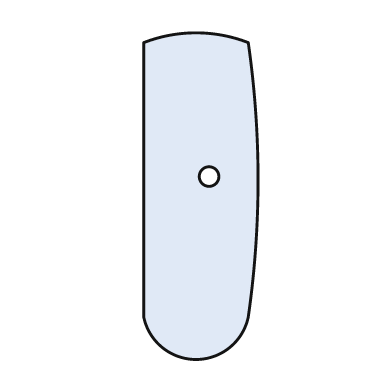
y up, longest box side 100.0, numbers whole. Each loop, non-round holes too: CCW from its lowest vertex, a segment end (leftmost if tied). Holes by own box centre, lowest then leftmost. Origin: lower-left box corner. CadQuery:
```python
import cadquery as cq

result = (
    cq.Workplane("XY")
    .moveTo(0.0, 13.0)
    .threePointArc((16.0, 0.0), (32.0, 13.0))
    .threePointArc((35.0, 55.0), (32.0, 97.0))
    .threePointArc((16.0, 100.0), (0.0, 97.0))
    .close()
    .moveTo(20.0, 56.0)
    .circle(3.0)
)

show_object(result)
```